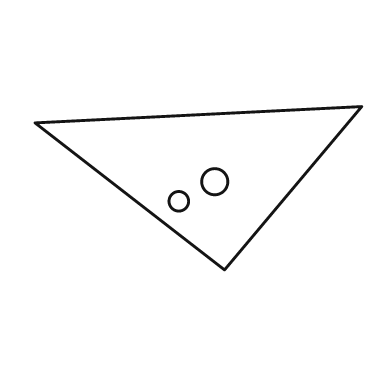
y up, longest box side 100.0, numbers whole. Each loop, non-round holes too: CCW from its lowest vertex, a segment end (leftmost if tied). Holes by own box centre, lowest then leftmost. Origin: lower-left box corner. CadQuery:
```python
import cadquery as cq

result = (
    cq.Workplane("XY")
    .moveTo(58.0, 0.0)
    .lineTo(100.0, 50.0)
    .lineTo(0.0, 45.0)
    .close()
    .moveTo(44.0, 21.0)
    .circle(3.0)
    .moveTo(55.0, 27.0)
    .circle(4.0)
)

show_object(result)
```